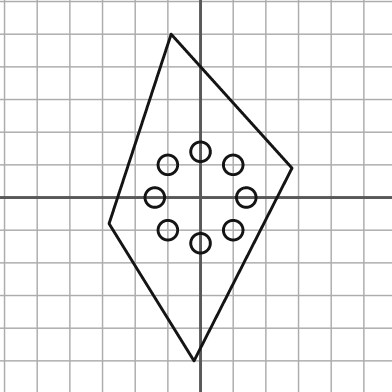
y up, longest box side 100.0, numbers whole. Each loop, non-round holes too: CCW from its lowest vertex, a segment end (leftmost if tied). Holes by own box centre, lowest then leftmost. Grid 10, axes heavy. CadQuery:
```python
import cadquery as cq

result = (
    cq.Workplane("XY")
    .moveTo(-2.0, -50.0)
    .lineTo(28.0, 9.0)
    .lineTo(-9.0, 50.0)
    .lineTo(-28.0, -8.0)
    .close()
    .moveTo(0.0, -14.0)
    .circle(3.0)
    .moveTo(-10.0, -10.0)
    .circle(3.0)
    .moveTo(10.0, -10.0)
    .circle(3.0)
    .moveTo(-14.0, 0.0)
    .circle(3.0)
    .moveTo(14.0, 0.0)
    .circle(3.0)
    .moveTo(-10.0, 10.0)
    .circle(3.0)
    .moveTo(10.0, 10.0)
    .circle(3.0)
    .moveTo(0.0, 14.0)
    .circle(3.0)
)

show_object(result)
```